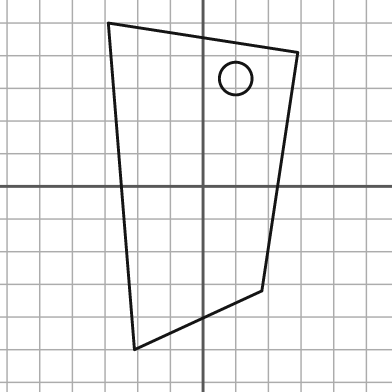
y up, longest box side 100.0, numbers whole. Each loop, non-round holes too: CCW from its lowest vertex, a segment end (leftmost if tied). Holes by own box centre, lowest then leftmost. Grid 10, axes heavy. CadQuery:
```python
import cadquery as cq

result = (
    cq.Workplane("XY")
    .moveTo(-21.0, -50.0)
    .lineTo(18.0, -32.0)
    .lineTo(29.0, 41.0)
    .lineTo(-29.0, 50.0)
    .close()
    .moveTo(10.0, 33.0)
    .circle(5.0)
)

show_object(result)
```